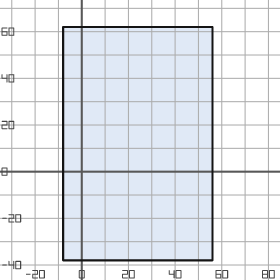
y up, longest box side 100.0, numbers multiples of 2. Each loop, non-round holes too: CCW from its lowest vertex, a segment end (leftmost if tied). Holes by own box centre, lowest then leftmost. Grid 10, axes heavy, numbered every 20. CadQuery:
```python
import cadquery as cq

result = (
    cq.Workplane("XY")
    .moveTo(-8.0, -38.0)
    .lineTo(56.0, -38.0)
    .lineTo(56.0, 62.0)
    .lineTo(-8.0, 62.0)
    .close()
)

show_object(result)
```